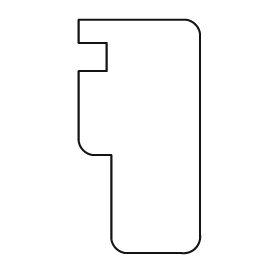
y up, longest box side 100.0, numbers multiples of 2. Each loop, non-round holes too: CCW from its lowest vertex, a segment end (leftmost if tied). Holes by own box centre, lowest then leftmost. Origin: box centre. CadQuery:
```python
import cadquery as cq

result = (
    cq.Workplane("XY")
    .moveTo(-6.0, -50.0)
    .lineTo(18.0, -50.0)
    .threePointArc((24.0, -48.0), (26.0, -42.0))
    .lineTo(26.0, 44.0)
    .threePointArc((24.0, 48.0), (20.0, 50.0))
    .lineTo(-26.0, 50.0)
    .lineTo(-26.0, 40.0)
    .lineTo(-14.0, 40.0)
    .lineTo(-14.0, 28.0)
    .lineTo(-26.0, 28.0)
    .lineTo(-26.0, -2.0)
    .threePointArc((-24.0, -6.0), (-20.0, -8.0))
    .lineTo(-12.0, -8.0)
    .lineTo(-12.0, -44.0)
    .threePointArc((-10.0, -48.0), (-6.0, -50.0))
    .close()
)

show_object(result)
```